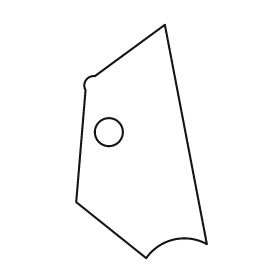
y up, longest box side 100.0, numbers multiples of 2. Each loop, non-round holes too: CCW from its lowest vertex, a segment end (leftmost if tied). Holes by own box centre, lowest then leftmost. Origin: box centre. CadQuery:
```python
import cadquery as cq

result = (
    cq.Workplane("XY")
    .moveTo(2.0, -50.0)
    .threePointArc((14.0, -42.0), (28.0, -44.0))
    .lineTo(10.0, 50.0)
    .lineTo(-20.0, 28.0)
    .threePointArc((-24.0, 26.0), (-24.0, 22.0))
    .lineTo(-28.0, -26.0)
    .close()
    .moveTo(-14.0, 4.0)
    .circle(6.0)
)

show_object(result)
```